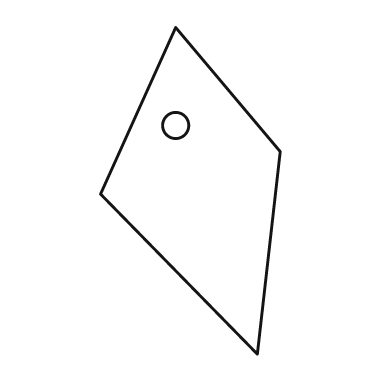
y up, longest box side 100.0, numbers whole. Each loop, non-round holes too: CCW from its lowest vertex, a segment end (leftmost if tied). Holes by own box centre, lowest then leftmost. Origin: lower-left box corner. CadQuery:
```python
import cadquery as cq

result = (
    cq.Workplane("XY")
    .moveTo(48.0, 0.0)
    .lineTo(55.0, 62.0)
    .lineTo(23.0, 100.0)
    .lineTo(0.0, 49.0)
    .close()
    .moveTo(23.0, 70.0)
    .circle(4.0)
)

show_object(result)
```